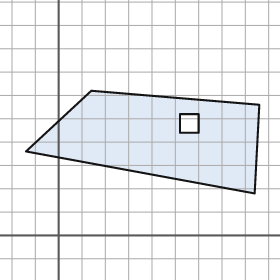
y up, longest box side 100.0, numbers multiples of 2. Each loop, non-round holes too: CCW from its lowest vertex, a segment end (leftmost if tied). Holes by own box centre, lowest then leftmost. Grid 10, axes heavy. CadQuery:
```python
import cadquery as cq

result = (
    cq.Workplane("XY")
    .moveTo(84.0, 18.0)
    .lineTo(86.0, 56.0)
    .lineTo(14.0, 62.0)
    .lineTo(-14.0, 36.0)
    .close()
    .moveTo(52.0, 44.0)
    .lineTo(60.0, 44.0)
    .lineTo(60.0, 52.0)
    .lineTo(52.0, 52.0)
    .close()
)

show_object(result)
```